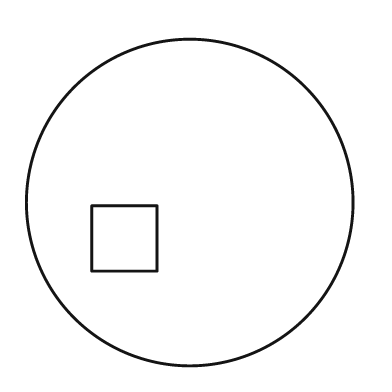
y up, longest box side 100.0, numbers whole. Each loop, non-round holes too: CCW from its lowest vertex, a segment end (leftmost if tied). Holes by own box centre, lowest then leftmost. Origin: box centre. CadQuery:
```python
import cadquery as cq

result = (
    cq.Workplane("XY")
    .moveTo(0.0, 0.0)
    .circle(50.0)
    .moveTo(-30.0, -21.0)
    .lineTo(-10.0, -21.0)
    .lineTo(-10.0, -1.0)
    .lineTo(-30.0, -1.0)
    .close()
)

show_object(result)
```